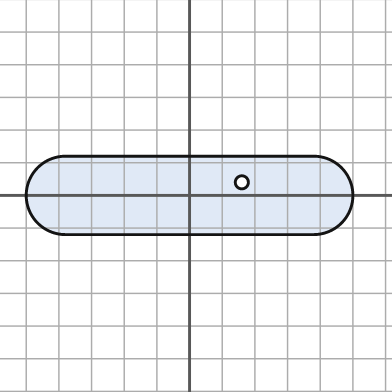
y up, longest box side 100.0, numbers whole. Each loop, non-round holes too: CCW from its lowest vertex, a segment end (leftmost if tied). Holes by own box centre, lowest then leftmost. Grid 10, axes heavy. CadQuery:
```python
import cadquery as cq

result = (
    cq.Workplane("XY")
    .moveTo(-38.0, -12.0)
    .lineTo(38.0, -12.0)
    .threePointArc((50.0, 0.0), (38.0, 12.0))
    .lineTo(-38.0, 12.0)
    .threePointArc((-50.0, 0.0), (-38.0, -12.0))
    .close()
    .moveTo(16.0, 4.0)
    .circle(2.0)
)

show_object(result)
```